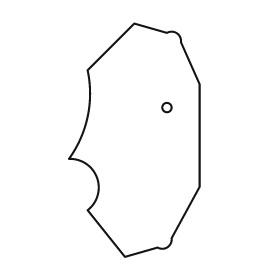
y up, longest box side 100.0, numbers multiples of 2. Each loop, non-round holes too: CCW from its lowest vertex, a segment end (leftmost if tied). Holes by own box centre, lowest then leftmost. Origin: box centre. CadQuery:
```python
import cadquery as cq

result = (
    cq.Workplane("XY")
    .moveTo(-4.0, -50.0)
    .lineTo(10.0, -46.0)
    .threePointArc((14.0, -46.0), (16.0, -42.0))
    .lineTo(28.0, -20.0)
    .lineTo(28.0, 24.0)
    .lineTo(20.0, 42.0)
    .threePointArc((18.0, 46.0), (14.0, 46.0))
    .lineTo(0.0, 50.0)
    .lineTo(-20.0, 30.0)
    .threePointArc((-20.0, 10.0), (-28.0, -8.0))
    .threePointArc((-16.0, -16.0), (-20.0, -30.0))
    .close()
    .moveTo(14.0, 14.0)
    .circle(2.0)
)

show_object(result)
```